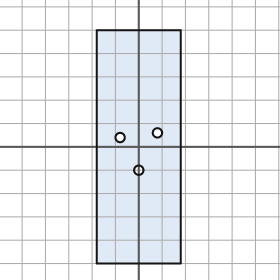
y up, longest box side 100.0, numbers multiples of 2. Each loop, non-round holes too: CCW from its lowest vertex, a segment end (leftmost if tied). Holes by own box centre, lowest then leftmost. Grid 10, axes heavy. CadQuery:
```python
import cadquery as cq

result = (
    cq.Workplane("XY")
    .moveTo(-18.0, -50.0)
    .lineTo(18.0, -50.0)
    .lineTo(18.0, 50.0)
    .lineTo(-18.0, 50.0)
    .close()
    .moveTo(0.0, -10.0)
    .circle(2.0)
    .moveTo(-8.0, 4.0)
    .circle(2.0)
    .moveTo(8.0, 6.0)
    .circle(2.0)
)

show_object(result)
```